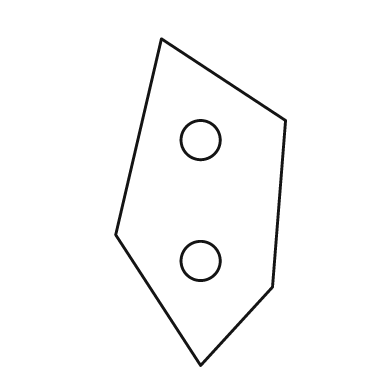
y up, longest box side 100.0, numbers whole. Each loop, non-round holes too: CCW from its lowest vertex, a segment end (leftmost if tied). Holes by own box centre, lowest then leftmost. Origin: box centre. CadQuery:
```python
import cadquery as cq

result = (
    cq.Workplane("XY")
    .moveTo(0.0, -50.0)
    .lineTo(22.0, -26.0)
    .lineTo(26.0, 25.0)
    .lineTo(-12.0, 50.0)
    .lineTo(-26.0, -10.0)
    .close()
    .moveTo(0.0, -18.0)
    .circle(6.0)
    .moveTo(0.0, 19.0)
    .circle(6.0)
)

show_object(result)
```